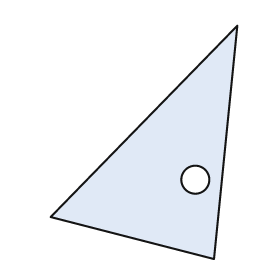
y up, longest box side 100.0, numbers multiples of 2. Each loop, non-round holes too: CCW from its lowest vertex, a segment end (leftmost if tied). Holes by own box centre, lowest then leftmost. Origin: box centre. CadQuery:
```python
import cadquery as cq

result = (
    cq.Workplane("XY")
    .moveTo(30.0, -50.0)
    .lineTo(40.0, 50.0)
    .lineTo(-40.0, -32.0)
    .close()
    .moveTo(22.0, -16.0)
    .circle(6.0)
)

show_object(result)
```